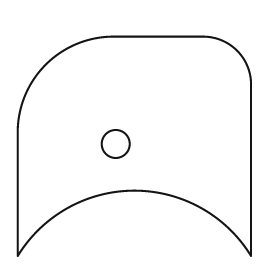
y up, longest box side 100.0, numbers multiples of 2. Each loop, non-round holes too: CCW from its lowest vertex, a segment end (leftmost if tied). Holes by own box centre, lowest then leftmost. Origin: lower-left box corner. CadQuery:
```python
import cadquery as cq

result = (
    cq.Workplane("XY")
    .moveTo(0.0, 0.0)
    .threePointArc((50.0, 28.0), (100.0, 0.0))
    .lineTo(100.0, 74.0)
    .threePointArc((94.0, 88.0), (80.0, 94.0))
    .lineTo(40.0, 94.0)
    .threePointArc((12.0, 82.0), (0.0, 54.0))
    .close()
    .moveTo(42.0, 48.0)
    .circle(6.0)
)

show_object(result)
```